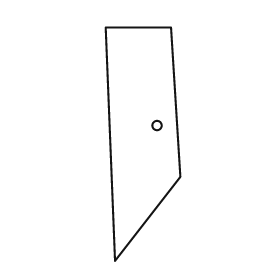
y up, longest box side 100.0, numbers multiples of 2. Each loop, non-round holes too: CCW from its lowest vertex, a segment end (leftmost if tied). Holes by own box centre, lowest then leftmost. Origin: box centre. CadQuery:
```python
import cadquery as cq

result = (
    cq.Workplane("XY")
    .moveTo(-12.0, -50.0)
    .lineTo(16.0, -14.0)
    .lineTo(12.0, 50.0)
    .lineTo(-16.0, 50.0)
    .close()
    .moveTo(6.0, 8.0)
    .circle(2.0)
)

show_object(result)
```